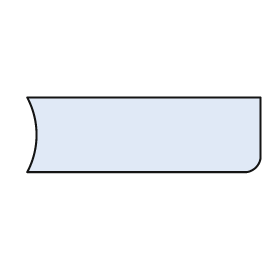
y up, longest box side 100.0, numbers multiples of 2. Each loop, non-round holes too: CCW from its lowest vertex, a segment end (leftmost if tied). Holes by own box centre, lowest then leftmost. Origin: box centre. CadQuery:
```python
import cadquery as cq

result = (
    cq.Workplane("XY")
    .moveTo(-50.0, -16.0)
    .lineTo(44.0, -16.0)
    .threePointArc((48.0, -14.0), (50.0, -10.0))
    .lineTo(50.0, 16.0)
    .lineTo(-50.0, 16.0)
    .threePointArc((-46.0, 0.0), (-50.0, -16.0))
    .close()
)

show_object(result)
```